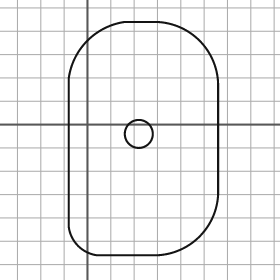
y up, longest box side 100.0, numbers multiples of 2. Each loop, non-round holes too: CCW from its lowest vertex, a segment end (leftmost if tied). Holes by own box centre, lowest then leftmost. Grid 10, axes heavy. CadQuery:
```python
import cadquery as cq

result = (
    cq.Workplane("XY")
    .moveTo(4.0, -56.0)
    .lineTo(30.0, -56.0)
    .threePointArc((48.0, -48.0), (56.0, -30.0))
    .lineTo(56.0, 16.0)
    .threePointArc((48.0, 36.0), (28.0, 44.0))
    .lineTo(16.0, 44.0)
    .threePointArc((0.0, 36.0), (-8.0, 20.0))
    .lineTo(-8.0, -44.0)
    .threePointArc((-4.0, -52.0), (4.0, -56.0))
    .close()
    .moveTo(22.0, -4.0)
    .circle(6.0)
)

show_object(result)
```